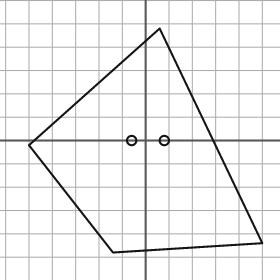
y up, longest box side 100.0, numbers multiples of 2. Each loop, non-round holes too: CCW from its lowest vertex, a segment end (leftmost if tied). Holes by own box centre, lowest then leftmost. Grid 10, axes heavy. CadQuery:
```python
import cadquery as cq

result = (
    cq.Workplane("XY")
    .moveTo(-14.0, -48.0)
    .lineTo(50.0, -44.0)
    .lineTo(6.0, 48.0)
    .lineTo(-50.0, -2.0)
    .close()
    .moveTo(-6.0, 0.0)
    .circle(2.0)
    .moveTo(8.0, 0.0)
    .circle(2.0)
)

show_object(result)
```